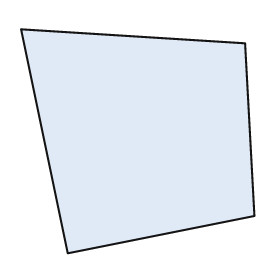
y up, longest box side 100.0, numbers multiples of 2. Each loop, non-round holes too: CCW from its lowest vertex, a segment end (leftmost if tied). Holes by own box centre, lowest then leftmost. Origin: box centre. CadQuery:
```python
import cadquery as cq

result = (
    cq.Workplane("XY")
    .moveTo(-30.0, -48.0)
    .lineTo(50.0, -32.0)
    .lineTo(46.0, 42.0)
    .lineTo(-50.0, 48.0)
    .close()
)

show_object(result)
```